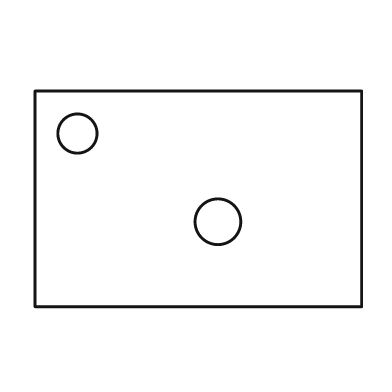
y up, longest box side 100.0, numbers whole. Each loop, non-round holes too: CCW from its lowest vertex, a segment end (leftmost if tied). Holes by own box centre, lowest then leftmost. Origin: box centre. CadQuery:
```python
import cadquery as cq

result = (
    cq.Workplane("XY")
    .moveTo(-50.0, -33.0)
    .lineTo(50.0, -33.0)
    .lineTo(50.0, 33.0)
    .lineTo(-50.0, 33.0)
    .close()
    .moveTo(6.0, -7.0)
    .circle(7.0)
    .moveTo(-37.0, 20.0)
    .circle(6.0)
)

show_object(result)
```